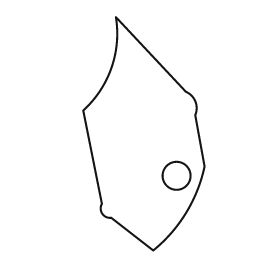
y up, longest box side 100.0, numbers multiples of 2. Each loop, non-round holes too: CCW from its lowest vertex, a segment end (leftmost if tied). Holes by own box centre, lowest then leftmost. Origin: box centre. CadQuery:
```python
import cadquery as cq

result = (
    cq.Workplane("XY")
    .moveTo(4.0, -50.0)
    .threePointArc((18.0, -34.0), (26.0, -14.0))
    .lineTo(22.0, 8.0)
    .threePointArc((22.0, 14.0), (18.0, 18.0))
    .lineTo(-12.0, 50.0)
    .threePointArc((-14.0, 28.0), (-26.0, 10.0))
    .lineTo(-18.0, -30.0)
    .threePointArc((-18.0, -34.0), (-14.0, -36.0))
    .close()
    .moveTo(14.0, -18.0)
    .circle(6.0)
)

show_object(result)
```